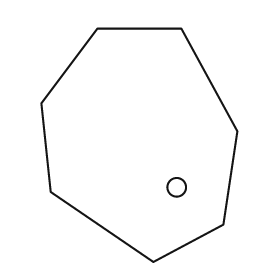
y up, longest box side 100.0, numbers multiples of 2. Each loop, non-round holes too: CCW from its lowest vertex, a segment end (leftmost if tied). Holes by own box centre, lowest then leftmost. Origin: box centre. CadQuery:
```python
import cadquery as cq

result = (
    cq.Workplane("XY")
    .moveTo(6.0, -50.0)
    .lineTo(36.0, -34.0)
    .lineTo(42.0, 6.0)
    .lineTo(18.0, 50.0)
    .lineTo(-18.0, 50.0)
    .lineTo(-42.0, 18.0)
    .lineTo(-38.0, -20.0)
    .close()
    .moveTo(16.0, -18.0)
    .circle(4.0)
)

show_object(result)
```